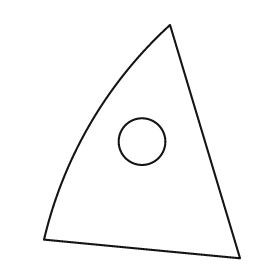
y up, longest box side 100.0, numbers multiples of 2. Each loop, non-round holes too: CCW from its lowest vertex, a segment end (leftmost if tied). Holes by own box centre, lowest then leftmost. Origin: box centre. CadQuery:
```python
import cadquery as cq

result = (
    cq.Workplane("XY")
    .moveTo(42.0, -50.0)
    .lineTo(12.0, 50.0)
    .threePointArc((-22.0, 8.0), (-42.0, -42.0))
    .close()
    .moveTo(0.0, 0.0)
    .circle(10.0)
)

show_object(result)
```